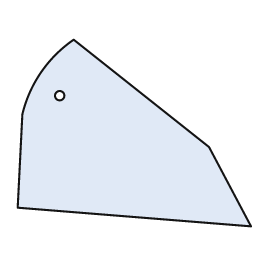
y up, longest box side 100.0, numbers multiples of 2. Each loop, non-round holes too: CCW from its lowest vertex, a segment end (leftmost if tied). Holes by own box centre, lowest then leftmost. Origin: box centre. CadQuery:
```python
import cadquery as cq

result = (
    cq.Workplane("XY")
    .moveTo(50.0, -40.0)
    .lineTo(32.0, -6.0)
    .lineTo(-26.0, 40.0)
    .threePointArc((-40.0, 26.0), (-48.0, 8.0))
    .lineTo(-50.0, -32.0)
    .close()
    .moveTo(-32.0, 16.0)
    .circle(2.0)
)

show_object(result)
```